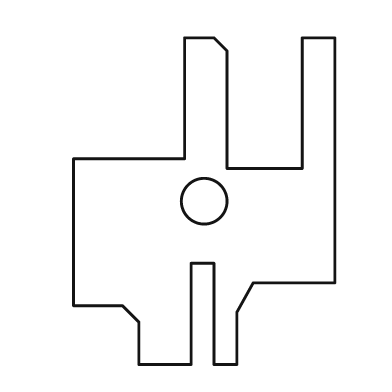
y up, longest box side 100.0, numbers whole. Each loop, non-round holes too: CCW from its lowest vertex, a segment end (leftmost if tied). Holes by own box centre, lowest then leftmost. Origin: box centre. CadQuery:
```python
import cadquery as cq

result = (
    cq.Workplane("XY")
    .moveTo(-20.0, -50.0)
    .lineTo(-4.0, -50.0)
    .lineTo(-4.0, -19.0)
    .lineTo(3.0, -19.0)
    .lineTo(3.0, -50.0)
    .lineTo(10.0, -50.0)
    .lineTo(10.0, -34.0)
    .lineTo(15.0, -25.0)
    .lineTo(40.0, -25.0)
    .lineTo(40.0, 50.0)
    .lineTo(30.0, 50.0)
    .lineTo(30.0, 10.0)
    .lineTo(7.0, 10.0)
    .lineTo(7.0, 46.0)
    .lineTo(3.0, 50.0)
    .lineTo(-6.0, 50.0)
    .lineTo(-6.0, 13.0)
    .lineTo(-40.0, 13.0)
    .lineTo(-40.0, -32.0)
    .lineTo(-25.0, -32.0)
    .lineTo(-20.0, -37.0)
    .close()
    .moveTo(0.0, 0.0)
    .circle(7.0)
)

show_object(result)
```